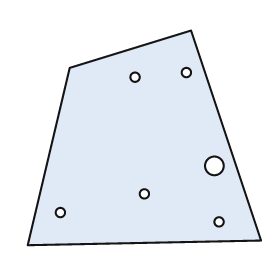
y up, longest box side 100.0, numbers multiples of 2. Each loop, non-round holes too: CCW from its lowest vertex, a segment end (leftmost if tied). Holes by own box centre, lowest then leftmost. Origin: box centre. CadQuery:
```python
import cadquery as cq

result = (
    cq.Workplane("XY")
    .moveTo(-50.0, -46.0)
    .lineTo(50.0, -44.0)
    .lineTo(20.0, 46.0)
    .lineTo(-32.0, 30.0)
    .close()
    .moveTo(32.0, -36.0)
    .circle(2.0)
    .moveTo(-36.0, -32.0)
    .circle(2.0)
    .moveTo(0.0, -24.0)
    .circle(2.0)
    .moveTo(30.0, -12.0)
    .circle(4.0)
    .moveTo(-4.0, 26.0)
    .circle(2.0)
    .moveTo(18.0, 28.0)
    .circle(2.0)
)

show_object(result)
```